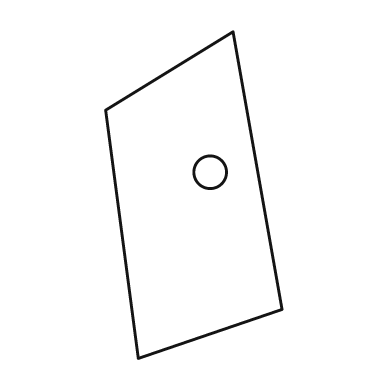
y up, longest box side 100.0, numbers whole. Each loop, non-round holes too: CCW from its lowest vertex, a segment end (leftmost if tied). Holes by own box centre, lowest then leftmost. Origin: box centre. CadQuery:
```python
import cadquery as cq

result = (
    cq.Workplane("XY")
    .moveTo(-17.0, -50.0)
    .lineTo(27.0, -35.0)
    .lineTo(12.0, 50.0)
    .lineTo(-27.0, 26.0)
    .close()
    .moveTo(5.0, 7.0)
    .circle(5.0)
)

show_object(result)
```